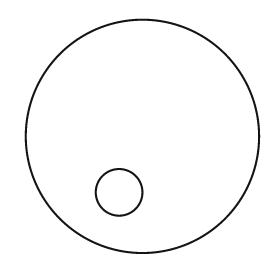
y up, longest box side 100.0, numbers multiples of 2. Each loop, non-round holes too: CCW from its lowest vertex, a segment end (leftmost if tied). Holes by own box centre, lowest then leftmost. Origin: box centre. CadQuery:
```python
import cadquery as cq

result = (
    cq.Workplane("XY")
    .moveTo(0.0, 0.0)
    .circle(50.0)
    .moveTo(-10.0, -24.0)
    .circle(10.0)
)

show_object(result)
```